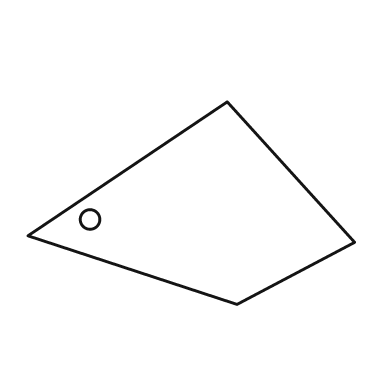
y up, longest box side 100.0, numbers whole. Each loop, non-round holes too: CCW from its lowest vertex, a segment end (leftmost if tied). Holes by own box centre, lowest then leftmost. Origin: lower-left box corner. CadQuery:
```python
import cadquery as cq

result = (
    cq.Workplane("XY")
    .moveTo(64.0, 0.0)
    .lineTo(100.0, 19.0)
    .lineTo(61.0, 62.0)
    .lineTo(0.0, 21.0)
    .close()
    .moveTo(19.0, 26.0)
    .circle(3.0)
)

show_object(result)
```